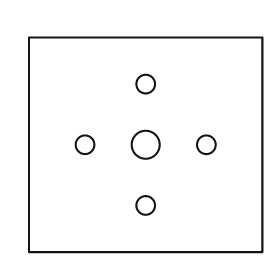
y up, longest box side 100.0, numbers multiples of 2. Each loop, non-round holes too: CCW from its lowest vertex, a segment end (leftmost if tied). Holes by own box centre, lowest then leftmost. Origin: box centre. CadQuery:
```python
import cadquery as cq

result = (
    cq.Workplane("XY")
    .moveTo(-50.0, -46.0)
    .lineTo(50.0, -46.0)
    .lineTo(50.0, 46.0)
    .lineTo(-50.0, 46.0)
    .close()
    .moveTo(0.0, -26.0)
    .circle(4.0)
    .moveTo(-26.0, 0.0)
    .circle(4.0)
    .moveTo(0.0, 0.0)
    .circle(6.0)
    .moveTo(26.0, 0.0)
    .circle(4.0)
    .moveTo(0.0, 26.0)
    .circle(4.0)
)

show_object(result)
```